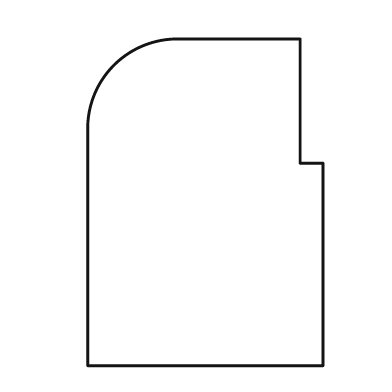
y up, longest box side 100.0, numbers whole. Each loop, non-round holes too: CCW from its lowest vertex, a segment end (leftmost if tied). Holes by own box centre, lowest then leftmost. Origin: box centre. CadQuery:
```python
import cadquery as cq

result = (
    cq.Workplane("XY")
    .moveTo(-36.0, -50.0)
    .lineTo(36.0, -50.0)
    .lineTo(36.0, 12.0)
    .lineTo(29.0, 12.0)
    .lineTo(29.0, 50.0)
    .lineTo(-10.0, 50.0)
    .threePointArc((-28.0, 42.0), (-36.0, 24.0))
    .close()
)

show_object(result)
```